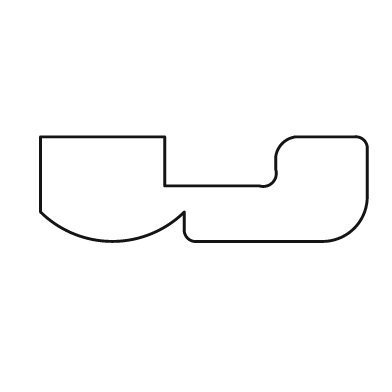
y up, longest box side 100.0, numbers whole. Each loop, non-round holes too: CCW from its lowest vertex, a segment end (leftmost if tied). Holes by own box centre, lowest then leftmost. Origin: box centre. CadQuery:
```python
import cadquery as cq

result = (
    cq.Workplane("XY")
    .moveTo(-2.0, -16.0)
    .lineTo(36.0, -16.0)
    .threePointArc((46.0, -12.0), (50.0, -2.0))
    .lineTo(50.0, 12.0)
    .threePointArc((49.0, 15.0), (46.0, 16.0))
    .lineTo(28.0, 16.0)
    .threePointArc((24.0, 14.0), (22.0, 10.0))
    .lineTo(22.0, 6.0)
    .threePointArc((21.0, 2.0), (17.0, 1.0))
    .lineTo(-12.0, 1.0)
    .lineTo(-12.0, 16.0)
    .lineTo(-50.0, 16.0)
    .lineTo(-50.0, -7.0)
    .threePointArc((-28.0, -16.0), (-6.0, -7.0))
    .lineTo(-6.0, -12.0)
    .threePointArc((-5.0, -15.0), (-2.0, -16.0))
    .close()
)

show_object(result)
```